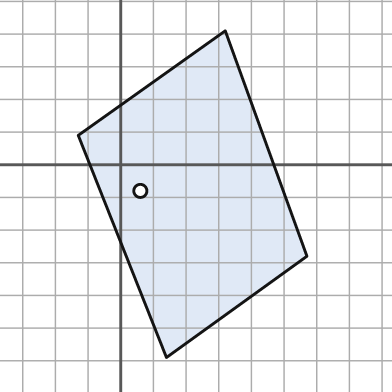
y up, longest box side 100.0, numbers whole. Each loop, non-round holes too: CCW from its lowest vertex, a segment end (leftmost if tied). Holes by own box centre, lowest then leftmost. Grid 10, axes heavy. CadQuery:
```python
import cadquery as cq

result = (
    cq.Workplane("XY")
    .moveTo(14.0, -59.0)
    .lineTo(57.0, -28.0)
    .lineTo(32.0, 41.0)
    .lineTo(-13.0, 9.0)
    .close()
    .moveTo(6.0, -8.0)
    .circle(2.0)
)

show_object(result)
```